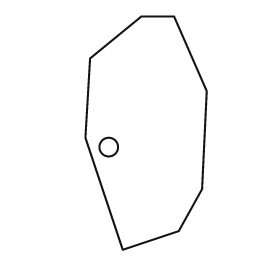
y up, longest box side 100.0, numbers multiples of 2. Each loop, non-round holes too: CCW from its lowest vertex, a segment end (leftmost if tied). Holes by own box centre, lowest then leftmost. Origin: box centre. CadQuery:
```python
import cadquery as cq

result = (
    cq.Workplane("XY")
    .moveTo(-10.0, -50.0)
    .lineTo(14.0, -42.0)
    .lineTo(24.0, -24.0)
    .lineTo(26.0, 18.0)
    .lineTo(12.0, 50.0)
    .lineTo(-2.0, 50.0)
    .lineTo(-24.0, 32.0)
    .lineTo(-26.0, -2.0)
    .close()
    .moveTo(-16.0, -6.0)
    .circle(4.0)
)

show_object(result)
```